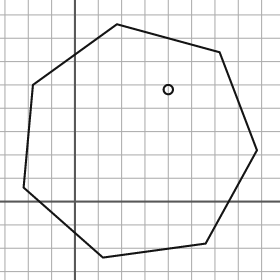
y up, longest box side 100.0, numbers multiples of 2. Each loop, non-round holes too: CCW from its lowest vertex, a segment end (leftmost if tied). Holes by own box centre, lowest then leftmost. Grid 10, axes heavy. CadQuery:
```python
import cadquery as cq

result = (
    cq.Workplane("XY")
    .moveTo(12.0, -24.0)
    .lineTo(56.0, -18.0)
    .lineTo(78.0, 22.0)
    .lineTo(62.0, 64.0)
    .lineTo(18.0, 76.0)
    .lineTo(-18.0, 50.0)
    .lineTo(-22.0, 6.0)
    .close()
    .moveTo(40.0, 48.0)
    .circle(2.0)
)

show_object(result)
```